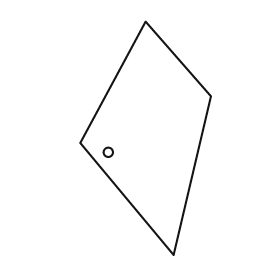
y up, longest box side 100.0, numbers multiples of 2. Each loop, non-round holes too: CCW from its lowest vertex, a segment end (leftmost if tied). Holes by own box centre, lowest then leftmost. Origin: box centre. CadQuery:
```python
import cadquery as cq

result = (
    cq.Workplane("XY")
    .moveTo(12.0, -50.0)
    .lineTo(28.0, 18.0)
    .lineTo(0.0, 50.0)
    .lineTo(-28.0, -2.0)
    .close()
    .moveTo(-16.0, -6.0)
    .circle(2.0)
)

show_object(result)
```